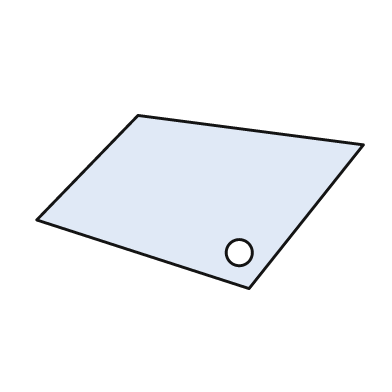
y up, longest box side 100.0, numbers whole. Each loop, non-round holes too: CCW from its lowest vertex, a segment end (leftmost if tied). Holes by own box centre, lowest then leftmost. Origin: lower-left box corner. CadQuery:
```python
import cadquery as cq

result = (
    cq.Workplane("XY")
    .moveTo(65.0, 0.0)
    .lineTo(100.0, 44.0)
    .lineTo(31.0, 53.0)
    .lineTo(0.0, 21.0)
    .close()
    .moveTo(62.0, 11.0)
    .circle(4.0)
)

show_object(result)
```